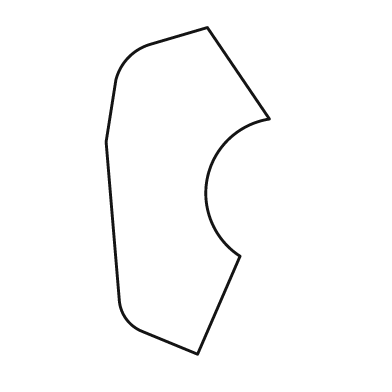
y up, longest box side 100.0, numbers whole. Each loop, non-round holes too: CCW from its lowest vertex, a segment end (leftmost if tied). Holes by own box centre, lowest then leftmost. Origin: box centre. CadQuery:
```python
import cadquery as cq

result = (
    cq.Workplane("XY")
    .moveTo(3.0, -50.0)
    .lineTo(16.0, -20.0)
    .threePointArc((6.0, 4.0), (25.0, 22.0))
    .lineTo(6.0, 50.0)
    .lineTo(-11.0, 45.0)
    .threePointArc((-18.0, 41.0), (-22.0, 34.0))
    .lineTo(-25.0, 15.0)
    .lineTo(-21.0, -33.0)
    .threePointArc((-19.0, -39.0), (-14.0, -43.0))
    .close()
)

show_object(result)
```